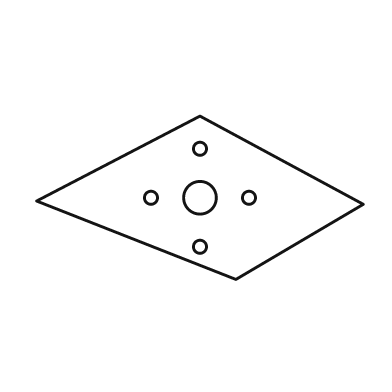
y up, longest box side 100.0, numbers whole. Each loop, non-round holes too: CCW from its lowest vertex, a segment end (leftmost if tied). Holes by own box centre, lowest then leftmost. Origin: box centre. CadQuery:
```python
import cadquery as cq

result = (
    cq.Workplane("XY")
    .moveTo(11.0, -25.0)
    .lineTo(50.0, -2.0)
    .lineTo(0.0, 25.0)
    .lineTo(-50.0, -1.0)
    .close()
    .moveTo(0.0, -15.0)
    .circle(2.0)
    .moveTo(-15.0, 0.0)
    .circle(2.0)
    .moveTo(0.0, 0.0)
    .circle(5.0)
    .moveTo(15.0, 0.0)
    .circle(2.0)
    .moveTo(0.0, 15.0)
    .circle(2.0)
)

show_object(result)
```